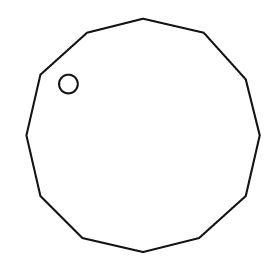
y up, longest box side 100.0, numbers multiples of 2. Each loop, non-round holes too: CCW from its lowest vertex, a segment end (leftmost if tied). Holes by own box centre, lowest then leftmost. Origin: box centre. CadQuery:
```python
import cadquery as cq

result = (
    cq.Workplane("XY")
    .moveTo(0.0, -50.0)
    .lineTo(24.0, -44.0)
    .lineTo(44.0, -26.0)
    .lineTo(50.0, 0.0)
    .lineTo(44.0, 24.0)
    .lineTo(26.0, 44.0)
    .lineTo(0.0, 50.0)
    .lineTo(-24.0, 44.0)
    .lineTo(-44.0, 26.0)
    .lineTo(-50.0, 0.0)
    .lineTo(-44.0, -26.0)
    .lineTo(-26.0, -44.0)
    .close()
    .moveTo(-32.0, 22.0)
    .circle(4.0)
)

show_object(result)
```